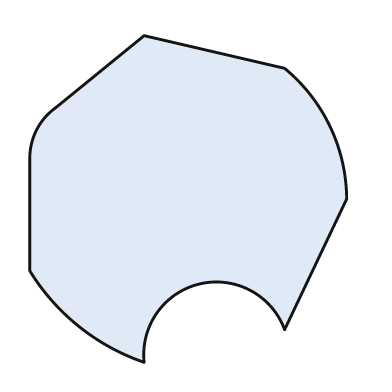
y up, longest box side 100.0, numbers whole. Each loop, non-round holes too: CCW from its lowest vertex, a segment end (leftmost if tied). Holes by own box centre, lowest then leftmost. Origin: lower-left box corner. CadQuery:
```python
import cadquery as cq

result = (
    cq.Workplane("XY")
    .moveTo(35.0, 0.0)
    .threePointArc((52.0, 24.0), (78.0, 10.0))
    .lineTo(97.0, 50.0)
    .threePointArc((92.0, 72.0), (78.0, 90.0))
    .lineTo(35.0, 100.0)
    .lineTo(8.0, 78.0)
    .threePointArc((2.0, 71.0), (0.0, 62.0))
    .lineTo(0.0, 28.0)
    .threePointArc((15.0, 11.0), (35.0, 0.0))
    .close()
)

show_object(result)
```